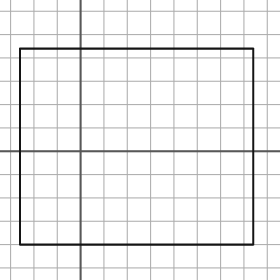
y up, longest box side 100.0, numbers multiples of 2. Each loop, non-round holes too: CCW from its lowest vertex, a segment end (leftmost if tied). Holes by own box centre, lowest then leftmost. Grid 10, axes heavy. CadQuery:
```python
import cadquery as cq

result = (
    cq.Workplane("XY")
    .moveTo(-26.0, -40.0)
    .lineTo(74.0, -40.0)
    .lineTo(74.0, 44.0)
    .lineTo(-26.0, 44.0)
    .close()
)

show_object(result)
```